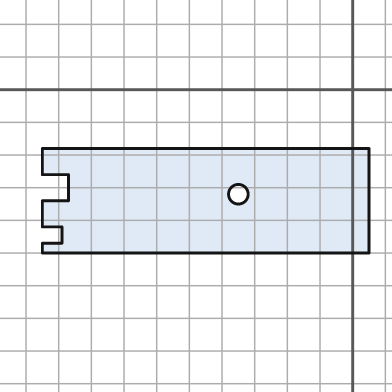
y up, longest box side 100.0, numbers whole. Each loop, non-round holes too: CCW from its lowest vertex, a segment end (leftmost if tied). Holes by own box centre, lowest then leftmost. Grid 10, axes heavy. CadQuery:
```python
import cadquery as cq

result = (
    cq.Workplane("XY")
    .moveTo(-95.0, -50.0)
    .lineTo(5.0, -50.0)
    .lineTo(5.0, -18.0)
    .lineTo(-95.0, -18.0)
    .lineTo(-95.0, -26.0)
    .lineTo(-87.0, -26.0)
    .lineTo(-87.0, -34.0)
    .lineTo(-95.0, -34.0)
    .lineTo(-95.0, -42.0)
    .lineTo(-89.0, -42.0)
    .lineTo(-89.0, -47.0)
    .lineTo(-95.0, -47.0)
    .close()
    .moveTo(-35.0, -32.0)
    .circle(3.0)
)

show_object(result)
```